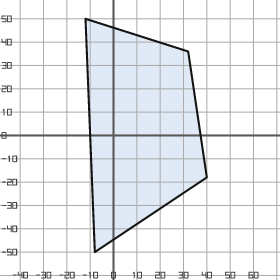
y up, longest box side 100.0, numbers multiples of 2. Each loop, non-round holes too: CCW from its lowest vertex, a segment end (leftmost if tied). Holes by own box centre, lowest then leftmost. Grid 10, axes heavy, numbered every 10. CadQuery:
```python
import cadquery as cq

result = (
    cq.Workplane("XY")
    .moveTo(-8.0, -50.0)
    .lineTo(40.0, -18.0)
    .lineTo(32.0, 36.0)
    .lineTo(-12.0, 50.0)
    .close()
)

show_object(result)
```